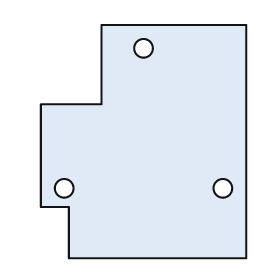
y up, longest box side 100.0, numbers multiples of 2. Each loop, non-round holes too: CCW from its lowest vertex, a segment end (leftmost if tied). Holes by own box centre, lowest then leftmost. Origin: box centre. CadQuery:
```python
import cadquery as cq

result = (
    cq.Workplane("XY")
    .moveTo(-32.0, -50.0)
    .lineTo(44.0, -50.0)
    .lineTo(44.0, 50.0)
    .lineTo(-18.0, 50.0)
    .lineTo(-18.0, 16.0)
    .lineTo(-44.0, 16.0)
    .lineTo(-44.0, -28.0)
    .lineTo(-32.0, -28.0)
    .close()
    .moveTo(-34.0, -20.0)
    .circle(4.0)
    .moveTo(34.0, -20.0)
    .circle(4.0)
    .moveTo(0.0, 40.0)
    .circle(4.0)
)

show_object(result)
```